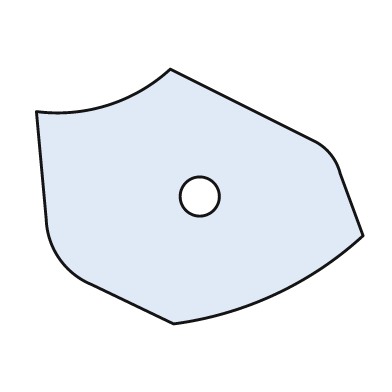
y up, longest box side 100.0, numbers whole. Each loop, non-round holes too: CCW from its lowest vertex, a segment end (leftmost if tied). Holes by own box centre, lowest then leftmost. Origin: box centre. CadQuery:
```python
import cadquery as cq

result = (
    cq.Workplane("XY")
    .moveTo(-8.0, -39.0)
    .threePointArc((23.0, -30.0), (50.0, -12.0))
    .lineTo(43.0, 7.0)
    .threePointArc((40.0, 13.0), (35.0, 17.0))
    .lineTo(-9.0, 39.0)
    .threePointArc((-28.0, 28.0), (-50.0, 26.0))
    .lineTo(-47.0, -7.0)
    .threePointArc((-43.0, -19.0), (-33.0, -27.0))
    .close()
    .moveTo(0.0, 0.0)
    .circle(6.0)
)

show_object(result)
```